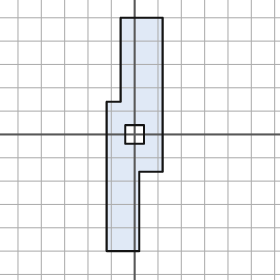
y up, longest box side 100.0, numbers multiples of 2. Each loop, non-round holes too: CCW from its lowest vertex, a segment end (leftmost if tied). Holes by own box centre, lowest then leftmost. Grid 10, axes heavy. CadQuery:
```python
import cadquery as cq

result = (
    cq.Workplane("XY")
    .moveTo(-12.0, -50.0)
    .lineTo(2.0, -50.0)
    .lineTo(2.0, -16.0)
    .lineTo(12.0, -16.0)
    .lineTo(12.0, 50.0)
    .lineTo(-6.0, 50.0)
    .lineTo(-6.0, 14.0)
    .lineTo(-12.0, 14.0)
    .close()
    .moveTo(-4.0, -4.0)
    .lineTo(4.0, -4.0)
    .lineTo(4.0, 4.0)
    .lineTo(-4.0, 4.0)
    .close()
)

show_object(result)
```